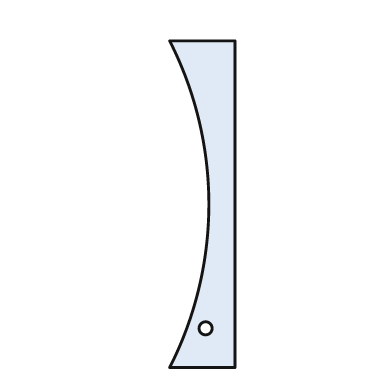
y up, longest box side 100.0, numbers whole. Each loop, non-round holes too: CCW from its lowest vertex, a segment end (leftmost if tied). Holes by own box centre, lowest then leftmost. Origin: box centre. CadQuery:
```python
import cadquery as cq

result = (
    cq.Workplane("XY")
    .moveTo(-10.0, -50.0)
    .lineTo(10.0, -50.0)
    .lineTo(10.0, 50.0)
    .lineTo(-10.0, 50.0)
    .threePointArc((2.0, 0.0), (-10.0, -50.0))
    .close()
    .moveTo(1.0, -38.0)
    .circle(2.0)
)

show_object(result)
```